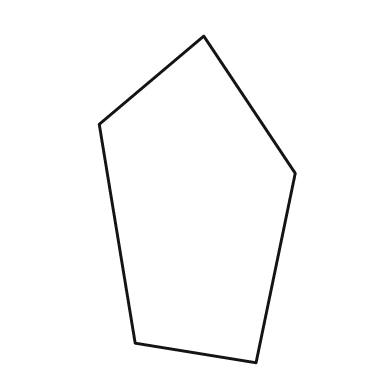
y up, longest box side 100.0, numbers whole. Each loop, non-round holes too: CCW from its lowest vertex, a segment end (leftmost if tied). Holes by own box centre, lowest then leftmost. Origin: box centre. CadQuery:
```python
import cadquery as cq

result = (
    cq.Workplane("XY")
    .moveTo(18.0, -50.0)
    .lineTo(30.0, 8.0)
    .lineTo(2.0, 50.0)
    .lineTo(-30.0, 23.0)
    .lineTo(-19.0, -44.0)
    .close()
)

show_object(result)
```